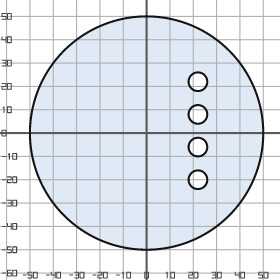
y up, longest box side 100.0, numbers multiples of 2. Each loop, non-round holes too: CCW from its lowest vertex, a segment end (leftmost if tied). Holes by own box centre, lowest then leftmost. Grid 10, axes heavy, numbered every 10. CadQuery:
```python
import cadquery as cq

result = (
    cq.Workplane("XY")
    .moveTo(0.0, 0.0)
    .circle(50.0)
    .moveTo(22.0, -20.0)
    .circle(4.0)
    .moveTo(22.0, -6.0)
    .circle(4.0)
    .moveTo(22.0, 8.0)
    .circle(4.0)
    .moveTo(22.0, 22.0)
    .circle(4.0)
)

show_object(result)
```